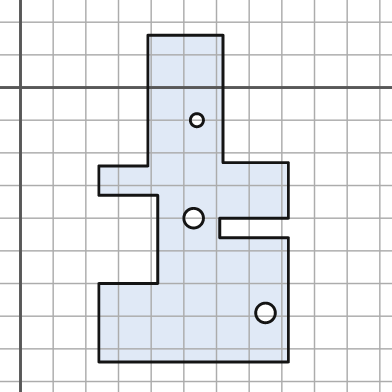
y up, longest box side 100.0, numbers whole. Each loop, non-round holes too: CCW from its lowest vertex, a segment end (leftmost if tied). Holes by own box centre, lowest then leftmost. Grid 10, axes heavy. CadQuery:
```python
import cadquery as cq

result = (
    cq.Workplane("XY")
    .moveTo(24.0, -84.0)
    .lineTo(82.0, -84.0)
    .lineTo(82.0, -46.0)
    .lineTo(61.0, -46.0)
    .lineTo(61.0, -40.0)
    .lineTo(82.0, -40.0)
    .lineTo(82.0, -23.0)
    .lineTo(62.0, -23.0)
    .lineTo(62.0, 16.0)
    .lineTo(39.0, 16.0)
    .lineTo(39.0, -24.0)
    .lineTo(24.0, -24.0)
    .lineTo(24.0, -33.0)
    .lineTo(42.0, -33.0)
    .lineTo(42.0, -60.0)
    .lineTo(24.0, -60.0)
    .close()
    .moveTo(75.0, -69.0)
    .circle(3.0)
    .moveTo(53.0, -40.0)
    .circle(3.0)
    .moveTo(54.0, -10.0)
    .circle(2.0)
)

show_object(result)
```